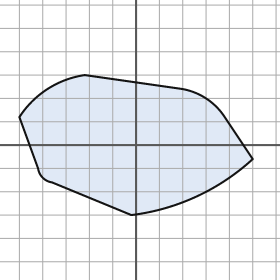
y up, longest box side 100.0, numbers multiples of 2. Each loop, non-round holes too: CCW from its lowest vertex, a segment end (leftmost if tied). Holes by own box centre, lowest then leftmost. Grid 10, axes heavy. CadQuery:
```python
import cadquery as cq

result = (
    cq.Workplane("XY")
    .moveTo(-2.0, -30.0)
    .threePointArc((26.0, -22.0), (50.0, -6.0))
    .lineTo(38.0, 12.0)
    .threePointArc((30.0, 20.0), (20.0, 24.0))
    .lineTo(-22.0, 30.0)
    .threePointArc((-38.0, 24.0), (-50.0, 12.0))
    .lineTo(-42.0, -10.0)
    .threePointArc((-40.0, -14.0), (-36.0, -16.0))
    .close()
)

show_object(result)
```